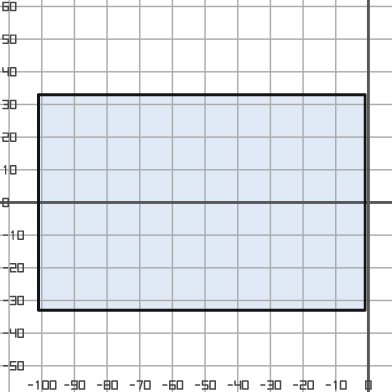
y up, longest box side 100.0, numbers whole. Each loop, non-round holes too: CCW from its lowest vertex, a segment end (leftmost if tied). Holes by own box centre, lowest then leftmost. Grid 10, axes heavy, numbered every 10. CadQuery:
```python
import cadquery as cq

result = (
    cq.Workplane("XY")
    .moveTo(-101.0, -33.0)
    .lineTo(-1.0, -33.0)
    .lineTo(-1.0, 33.0)
    .lineTo(-101.0, 33.0)
    .close()
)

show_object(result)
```